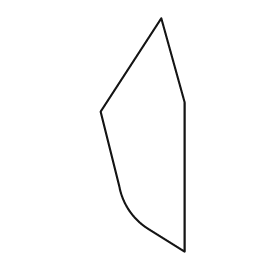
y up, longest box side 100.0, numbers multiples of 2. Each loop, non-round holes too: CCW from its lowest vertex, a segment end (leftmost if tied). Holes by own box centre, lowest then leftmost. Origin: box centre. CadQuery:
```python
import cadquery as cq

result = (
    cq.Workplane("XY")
    .moveTo(18.0, -50.0)
    .lineTo(18.0, 14.0)
    .lineTo(8.0, 50.0)
    .lineTo(-18.0, 10.0)
    .lineTo(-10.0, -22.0)
    .threePointArc((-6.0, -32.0), (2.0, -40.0))
    .close()
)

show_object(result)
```